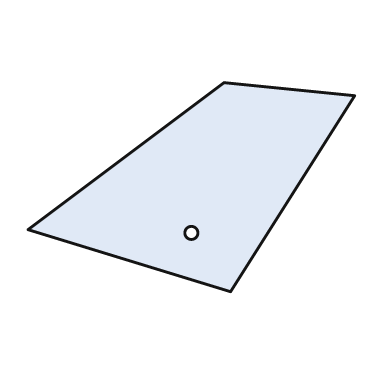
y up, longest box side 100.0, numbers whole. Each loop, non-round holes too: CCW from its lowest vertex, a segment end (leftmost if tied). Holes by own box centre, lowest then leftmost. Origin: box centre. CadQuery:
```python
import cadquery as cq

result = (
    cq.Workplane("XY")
    .moveTo(12.0, -32.0)
    .lineTo(50.0, 28.0)
    .lineTo(10.0, 32.0)
    .lineTo(-50.0, -13.0)
    .close()
    .moveTo(0.0, -14.0)
    .circle(2.0)
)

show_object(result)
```